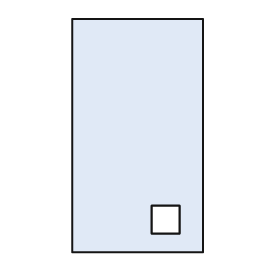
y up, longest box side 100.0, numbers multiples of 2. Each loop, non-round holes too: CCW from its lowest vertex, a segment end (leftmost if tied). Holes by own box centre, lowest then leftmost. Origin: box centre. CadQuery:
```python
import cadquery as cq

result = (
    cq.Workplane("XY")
    .moveTo(-28.0, -50.0)
    .lineTo(28.0, -50.0)
    .lineTo(28.0, 50.0)
    .lineTo(-28.0, 50.0)
    .close()
    .moveTo(6.0, -42.0)
    .lineTo(18.0, -42.0)
    .lineTo(18.0, -30.0)
    .lineTo(6.0, -30.0)
    .close()
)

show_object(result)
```